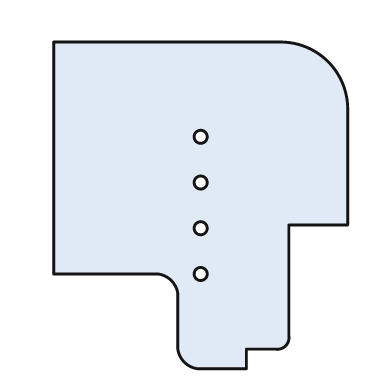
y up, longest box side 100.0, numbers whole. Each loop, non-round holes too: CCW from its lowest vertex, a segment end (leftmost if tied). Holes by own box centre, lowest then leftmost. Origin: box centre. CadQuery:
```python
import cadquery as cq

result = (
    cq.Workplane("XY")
    .moveTo(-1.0, -50.0)
    .lineTo(14.0, -50.0)
    .lineTo(14.0, -44.0)
    .lineTo(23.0, -44.0)
    .threePointArc((26.0, -43.0), (27.0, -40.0))
    .lineTo(27.0, -6.0)
    .lineTo(45.0, -6.0)
    .lineTo(45.0, 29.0)
    .threePointArc((39.0, 44.0), (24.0, 50.0))
    .lineTo(-45.0, 50.0)
    .lineTo(-45.0, -21.0)
    .lineTo(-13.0, -21.0)
    .threePointArc((-9.0, -23.0), (-7.0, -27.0))
    .lineTo(-7.0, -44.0)
    .threePointArc((-5.0, -48.0), (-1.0, -50.0))
    .close()
    .moveTo(0.0, -21.0)
    .circle(2.0)
    .moveTo(0.0, -7.0)
    .circle(2.0)
    .moveTo(0.0, 7.0)
    .circle(2.0)
    .moveTo(0.0, 21.0)
    .circle(2.0)
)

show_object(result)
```